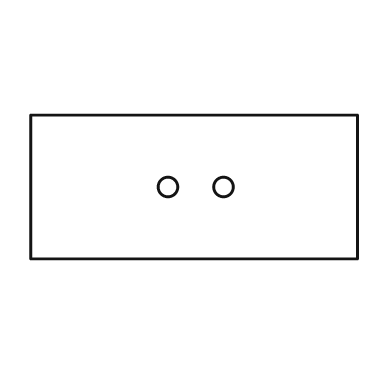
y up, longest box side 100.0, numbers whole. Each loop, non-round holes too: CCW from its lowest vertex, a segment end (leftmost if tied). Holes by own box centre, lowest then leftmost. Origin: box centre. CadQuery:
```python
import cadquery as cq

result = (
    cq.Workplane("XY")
    .moveTo(-50.0, -22.0)
    .lineTo(50.0, -22.0)
    .lineTo(50.0, 22.0)
    .lineTo(-50.0, 22.0)
    .close()
    .moveTo(-8.0, 0.0)
    .circle(3.0)
    .moveTo(9.0, 0.0)
    .circle(3.0)
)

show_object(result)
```